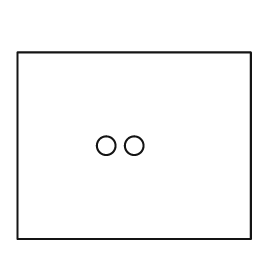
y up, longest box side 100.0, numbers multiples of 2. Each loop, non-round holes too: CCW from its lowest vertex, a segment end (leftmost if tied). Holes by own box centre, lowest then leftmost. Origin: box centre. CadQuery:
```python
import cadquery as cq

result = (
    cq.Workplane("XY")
    .moveTo(-50.0, -40.0)
    .lineTo(50.0, -40.0)
    .lineTo(50.0, 40.0)
    .lineTo(-50.0, 40.0)
    .close()
    .moveTo(-12.0, 0.0)
    .circle(4.0)
    .moveTo(0.0, 0.0)
    .circle(4.0)
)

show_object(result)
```